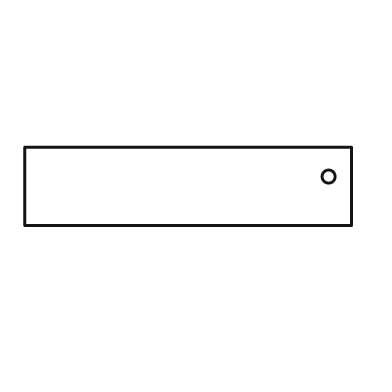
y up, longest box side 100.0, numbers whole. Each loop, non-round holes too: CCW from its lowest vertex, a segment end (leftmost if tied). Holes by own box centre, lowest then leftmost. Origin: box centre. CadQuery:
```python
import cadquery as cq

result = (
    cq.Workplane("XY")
    .moveTo(-50.0, -12.0)
    .lineTo(50.0, -12.0)
    .lineTo(50.0, 12.0)
    .lineTo(-50.0, 12.0)
    .close()
    .moveTo(43.0, 3.0)
    .circle(2.0)
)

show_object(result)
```